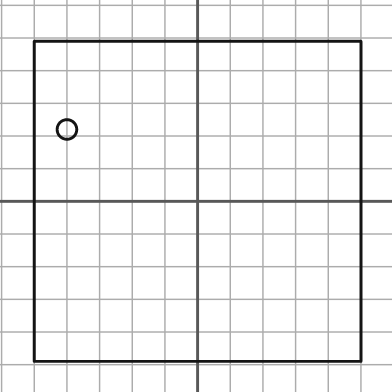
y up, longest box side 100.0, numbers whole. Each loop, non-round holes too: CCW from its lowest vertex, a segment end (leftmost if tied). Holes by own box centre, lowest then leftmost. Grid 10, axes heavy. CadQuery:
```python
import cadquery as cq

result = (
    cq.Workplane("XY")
    .moveTo(-50.0, -49.0)
    .lineTo(50.0, -49.0)
    .lineTo(50.0, 49.0)
    .lineTo(-50.0, 49.0)
    .close()
    .moveTo(-40.0, 22.0)
    .circle(3.0)
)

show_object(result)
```